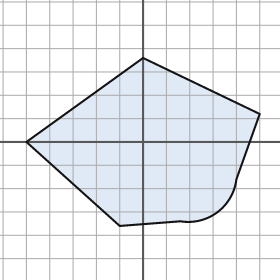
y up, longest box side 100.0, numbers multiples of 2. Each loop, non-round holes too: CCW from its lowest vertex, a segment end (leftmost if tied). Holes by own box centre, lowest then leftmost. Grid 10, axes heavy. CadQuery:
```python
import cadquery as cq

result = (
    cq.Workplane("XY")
    .moveTo(-10.0, -36.0)
    .lineTo(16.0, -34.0)
    .threePointArc((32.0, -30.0), (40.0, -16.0))
    .lineTo(50.0, 12.0)
    .lineTo(0.0, 36.0)
    .lineTo(-50.0, 0.0)
    .close()
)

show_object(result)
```